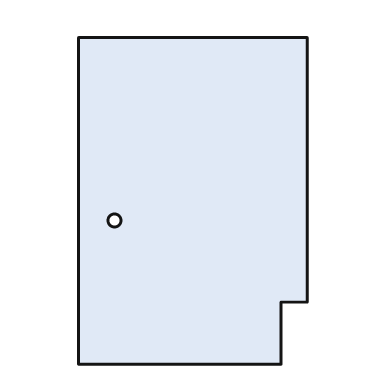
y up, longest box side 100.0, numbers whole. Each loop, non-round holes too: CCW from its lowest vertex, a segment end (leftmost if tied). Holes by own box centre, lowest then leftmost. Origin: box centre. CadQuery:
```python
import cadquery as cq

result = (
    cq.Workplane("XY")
    .moveTo(-35.0, -50.0)
    .lineTo(27.0, -50.0)
    .lineTo(27.0, -31.0)
    .lineTo(35.0, -31.0)
    .lineTo(35.0, 50.0)
    .lineTo(-35.0, 50.0)
    .close()
    .moveTo(-24.0, -6.0)
    .circle(2.0)
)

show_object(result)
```